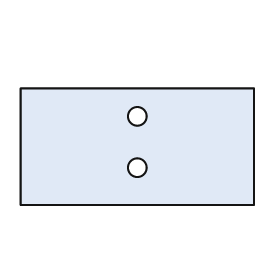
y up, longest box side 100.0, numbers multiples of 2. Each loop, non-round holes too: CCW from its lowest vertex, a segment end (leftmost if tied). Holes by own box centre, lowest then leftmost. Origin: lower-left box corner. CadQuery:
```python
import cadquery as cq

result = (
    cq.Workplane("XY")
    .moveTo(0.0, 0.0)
    .lineTo(100.0, 0.0)
    .lineTo(100.0, 50.0)
    .lineTo(0.0, 50.0)
    .close()
    .moveTo(50.0, 16.0)
    .circle(4.0)
    .moveTo(50.0, 38.0)
    .circle(4.0)
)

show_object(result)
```